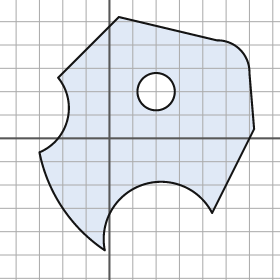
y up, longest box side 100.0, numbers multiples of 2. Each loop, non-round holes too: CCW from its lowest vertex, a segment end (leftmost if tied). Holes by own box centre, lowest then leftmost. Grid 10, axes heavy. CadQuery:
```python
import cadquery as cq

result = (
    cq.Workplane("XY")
    .moveTo(-2.0, -48.0)
    .threePointArc((14.0, -20.0), (44.0, -32.0))
    .lineTo(62.0, 4.0)
    .lineTo(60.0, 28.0)
    .threePointArc((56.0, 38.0), (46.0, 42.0))
    .lineTo(4.0, 52.0)
    .lineTo(-22.0, 26.0)
    .threePointArc((-18.0, 8.0), (-30.0, -6.0))
    .threePointArc((-20.0, -30.0), (-2.0, -48.0))
    .close()
    .moveTo(20.0, 20.0)
    .circle(8.0)
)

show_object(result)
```